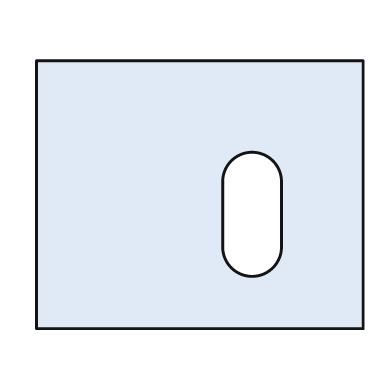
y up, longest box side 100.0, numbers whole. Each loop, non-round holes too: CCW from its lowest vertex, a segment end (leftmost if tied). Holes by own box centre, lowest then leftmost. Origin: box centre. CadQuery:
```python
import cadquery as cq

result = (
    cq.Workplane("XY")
    .moveTo(-50.0, -41.0)
    .lineTo(50.0, -41.0)
    .lineTo(50.0, 41.0)
    .lineTo(-50.0, 41.0)
    .close()
    .moveTo(7.0, -16.0)
    .threePointArc((16.0, -25.0), (25.0, -16.0))
    .lineTo(25.0, 4.0)
    .threePointArc((16.0, 13.0), (7.0, 4.0))
    .close()
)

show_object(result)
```